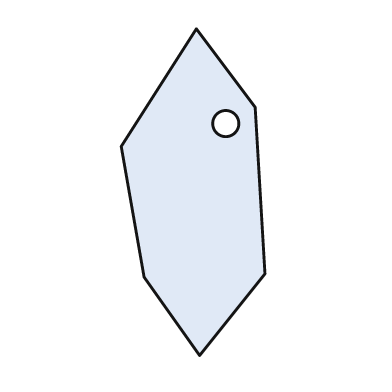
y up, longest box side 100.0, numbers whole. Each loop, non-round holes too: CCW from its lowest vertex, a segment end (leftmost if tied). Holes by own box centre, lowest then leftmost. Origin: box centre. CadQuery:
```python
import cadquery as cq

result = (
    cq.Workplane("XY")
    .moveTo(2.0, -50.0)
    .lineTo(22.0, -25.0)
    .lineTo(19.0, 26.0)
    .lineTo(1.0, 50.0)
    .lineTo(-22.0, 14.0)
    .lineTo(-15.0, -26.0)
    .close()
    .moveTo(10.0, 21.0)
    .circle(4.0)
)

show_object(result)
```